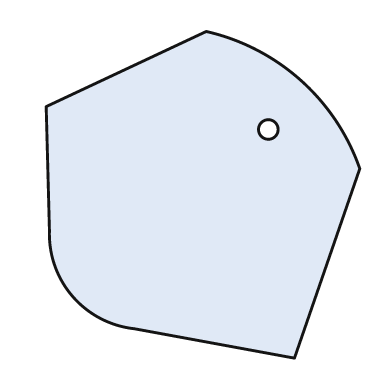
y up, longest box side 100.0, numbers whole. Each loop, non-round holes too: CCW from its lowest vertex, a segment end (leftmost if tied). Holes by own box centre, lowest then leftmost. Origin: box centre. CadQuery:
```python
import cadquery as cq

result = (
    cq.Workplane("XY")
    .moveTo(28.0, -50.0)
    .lineTo(48.0, 8.0)
    .threePointArc((30.0, 35.0), (1.0, 50.0))
    .lineTo(-48.0, 27.0)
    .lineTo(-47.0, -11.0)
    .threePointArc((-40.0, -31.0), (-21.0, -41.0))
    .close()
    .moveTo(20.0, 20.0)
    .circle(3.0)
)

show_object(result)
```